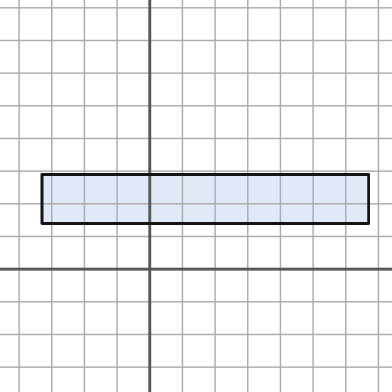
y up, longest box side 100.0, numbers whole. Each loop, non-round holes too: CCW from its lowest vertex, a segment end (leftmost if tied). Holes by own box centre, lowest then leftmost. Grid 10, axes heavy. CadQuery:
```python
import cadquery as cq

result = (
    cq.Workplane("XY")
    .moveTo(-33.0, 14.0)
    .lineTo(67.0, 14.0)
    .lineTo(67.0, 29.0)
    .lineTo(-33.0, 29.0)
    .close()
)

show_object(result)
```